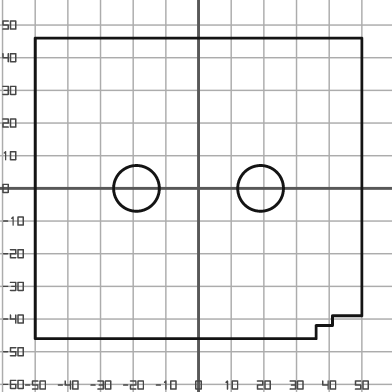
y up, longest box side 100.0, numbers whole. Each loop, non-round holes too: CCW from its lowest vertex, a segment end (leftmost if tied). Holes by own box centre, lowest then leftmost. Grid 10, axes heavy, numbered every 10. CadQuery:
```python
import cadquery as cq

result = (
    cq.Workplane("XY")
    .moveTo(-50.0, -46.0)
    .lineTo(36.0, -46.0)
    .lineTo(36.0, -42.0)
    .lineTo(41.0, -42.0)
    .lineTo(41.0, -39.0)
    .lineTo(50.0, -39.0)
    .lineTo(50.0, 46.0)
    .lineTo(-50.0, 46.0)
    .close()
    .moveTo(-19.0, 0.0)
    .circle(7.0)
    .moveTo(19.0, 0.0)
    .circle(7.0)
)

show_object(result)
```